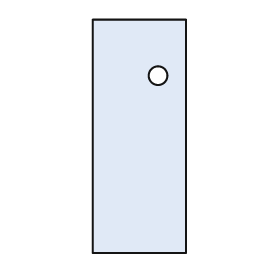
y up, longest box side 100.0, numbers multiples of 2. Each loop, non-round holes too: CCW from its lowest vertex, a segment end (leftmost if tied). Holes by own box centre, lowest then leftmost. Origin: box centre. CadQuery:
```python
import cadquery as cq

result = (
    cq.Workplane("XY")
    .moveTo(-20.0, -50.0)
    .lineTo(20.0, -50.0)
    .lineTo(20.0, 50.0)
    .lineTo(-20.0, 50.0)
    .close()
    .moveTo(8.0, 26.0)
    .circle(4.0)
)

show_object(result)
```